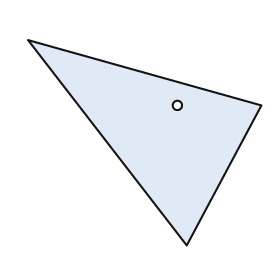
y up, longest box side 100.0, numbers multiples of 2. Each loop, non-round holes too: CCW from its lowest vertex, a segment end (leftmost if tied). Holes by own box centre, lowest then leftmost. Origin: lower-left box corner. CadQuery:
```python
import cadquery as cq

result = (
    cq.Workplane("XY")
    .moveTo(68.0, 0.0)
    .lineTo(100.0, 60.0)
    .lineTo(0.0, 88.0)
    .close()
    .moveTo(64.0, 60.0)
    .circle(2.0)
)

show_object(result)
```